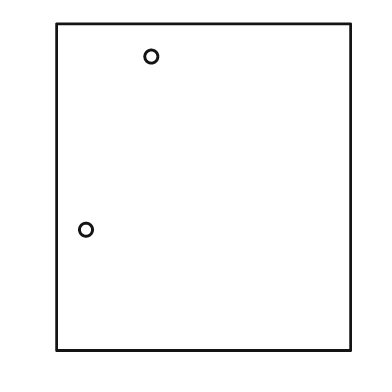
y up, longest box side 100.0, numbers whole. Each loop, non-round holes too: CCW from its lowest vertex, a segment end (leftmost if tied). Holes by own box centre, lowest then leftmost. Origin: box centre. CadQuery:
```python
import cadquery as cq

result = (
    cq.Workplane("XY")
    .moveTo(-45.0, -50.0)
    .lineTo(45.0, -50.0)
    .lineTo(45.0, 50.0)
    .lineTo(-45.0, 50.0)
    .close()
    .moveTo(-36.0, -13.0)
    .circle(2.0)
    .moveTo(-16.0, 40.0)
    .circle(2.0)
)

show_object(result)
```